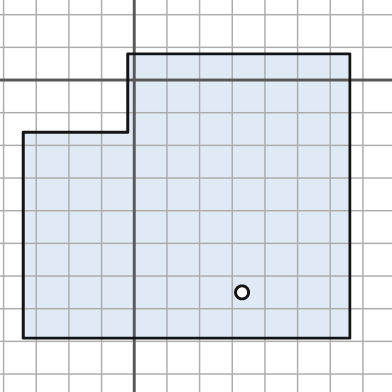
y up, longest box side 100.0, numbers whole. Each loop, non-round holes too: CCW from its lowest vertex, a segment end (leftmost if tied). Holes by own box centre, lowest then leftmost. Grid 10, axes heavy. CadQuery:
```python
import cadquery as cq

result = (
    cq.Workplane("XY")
    .moveTo(-34.0, -79.0)
    .lineTo(66.0, -79.0)
    .lineTo(66.0, 8.0)
    .lineTo(-2.0, 8.0)
    .lineTo(-2.0, -16.0)
    .lineTo(-34.0, -16.0)
    .close()
    .moveTo(33.0, -65.0)
    .circle(2.0)
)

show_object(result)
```